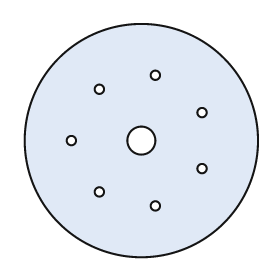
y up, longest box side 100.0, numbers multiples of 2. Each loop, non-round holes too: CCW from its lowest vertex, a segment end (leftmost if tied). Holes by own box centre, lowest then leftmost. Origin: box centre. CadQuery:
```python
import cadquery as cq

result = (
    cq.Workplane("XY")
    .moveTo(0.0, 0.0)
    .circle(50.0)
    .moveTo(6.0, -28.0)
    .circle(2.0)
    .moveTo(-18.0, -22.0)
    .circle(2.0)
    .moveTo(26.0, -12.0)
    .circle(2.0)
    .moveTo(-30.0, 0.0)
    .circle(2.0)
    .moveTo(0.0, 0.0)
    .circle(6.0)
    .moveTo(26.0, 12.0)
    .circle(2.0)
    .moveTo(-18.0, 22.0)
    .circle(2.0)
    .moveTo(6.0, 28.0)
    .circle(2.0)
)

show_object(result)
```